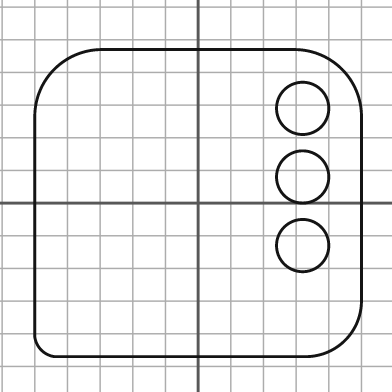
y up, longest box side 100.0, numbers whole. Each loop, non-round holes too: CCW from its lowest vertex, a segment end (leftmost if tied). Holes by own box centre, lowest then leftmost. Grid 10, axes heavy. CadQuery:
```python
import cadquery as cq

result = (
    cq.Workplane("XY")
    .moveTo(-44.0, -47.0)
    .lineTo(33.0, -47.0)
    .threePointArc((45.0, -42.0), (50.0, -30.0))
    .lineTo(50.0, 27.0)
    .threePointArc((44.0, 41.0), (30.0, 47.0))
    .lineTo(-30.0, 47.0)
    .threePointArc((-44.0, 41.0), (-50.0, 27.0))
    .lineTo(-50.0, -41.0)
    .threePointArc((-48.0, -45.0), (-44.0, -47.0))
    .close()
    .moveTo(32.0, -13.0)
    .circle(8.0)
    .moveTo(32.0, 8.0)
    .circle(8.0)
    .moveTo(32.0, 29.0)
    .circle(8.0)
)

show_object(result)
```